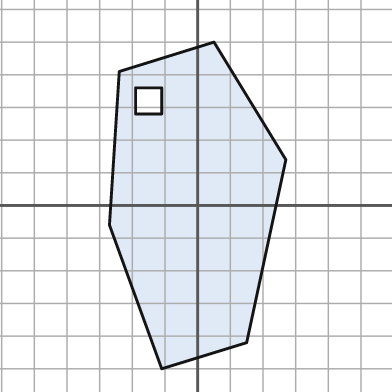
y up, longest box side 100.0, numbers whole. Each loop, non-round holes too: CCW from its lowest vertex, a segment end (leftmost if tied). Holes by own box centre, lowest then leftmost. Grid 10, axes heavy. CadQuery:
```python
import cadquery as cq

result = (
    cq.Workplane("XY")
    .moveTo(-11.0, -50.0)
    .lineTo(15.0, -42.0)
    .lineTo(27.0, 14.0)
    .lineTo(5.0, 50.0)
    .lineTo(-24.0, 41.0)
    .lineTo(-27.0, -6.0)
    .close()
    .moveTo(-19.0, 28.0)
    .lineTo(-11.0, 28.0)
    .lineTo(-11.0, 36.0)
    .lineTo(-19.0, 36.0)
    .close()
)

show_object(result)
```